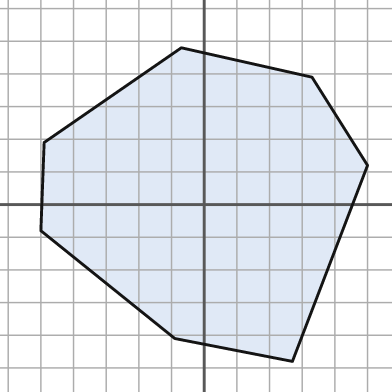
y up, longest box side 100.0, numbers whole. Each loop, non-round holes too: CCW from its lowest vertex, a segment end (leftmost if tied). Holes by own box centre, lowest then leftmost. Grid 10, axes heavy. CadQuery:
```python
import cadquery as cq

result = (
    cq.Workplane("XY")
    .moveTo(27.0, -48.0)
    .lineTo(50.0, 12.0)
    .lineTo(33.0, 39.0)
    .lineTo(-7.0, 48.0)
    .lineTo(-49.0, 19.0)
    .lineTo(-50.0, -8.0)
    .lineTo(-9.0, -41.0)
    .close()
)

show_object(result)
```